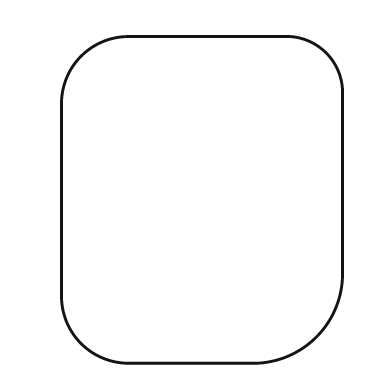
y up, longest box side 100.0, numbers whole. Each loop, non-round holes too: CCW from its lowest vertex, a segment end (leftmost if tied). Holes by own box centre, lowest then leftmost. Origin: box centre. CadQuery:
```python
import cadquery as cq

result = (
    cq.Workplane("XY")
    .moveTo(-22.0, -50.0)
    .lineTo(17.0, -50.0)
    .threePointArc((35.0, -42.0), (43.0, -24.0))
    .lineTo(43.0, 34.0)
    .threePointArc((38.0, 45.0), (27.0, 50.0))
    .lineTo(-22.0, 50.0)
    .threePointArc((-37.0, 44.0), (-43.0, 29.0))
    .lineTo(-43.0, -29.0)
    .threePointArc((-37.0, -44.0), (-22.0, -50.0))
    .close()
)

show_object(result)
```